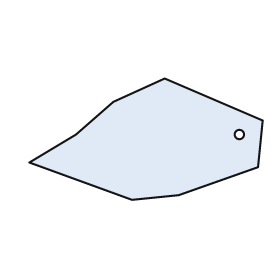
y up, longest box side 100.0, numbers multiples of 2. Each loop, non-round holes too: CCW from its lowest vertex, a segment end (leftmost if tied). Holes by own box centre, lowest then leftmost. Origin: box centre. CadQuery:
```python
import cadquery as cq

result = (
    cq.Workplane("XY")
    .moveTo(-6.0, -26.0)
    .lineTo(14.0, -24.0)
    .lineTo(48.0, -12.0)
    .lineTo(50.0, 8.0)
    .lineTo(8.0, 26.0)
    .lineTo(-14.0, 16.0)
    .lineTo(-30.0, 2.0)
    .lineTo(-50.0, -10.0)
    .close()
    .moveTo(40.0, 2.0)
    .circle(2.0)
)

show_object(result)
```